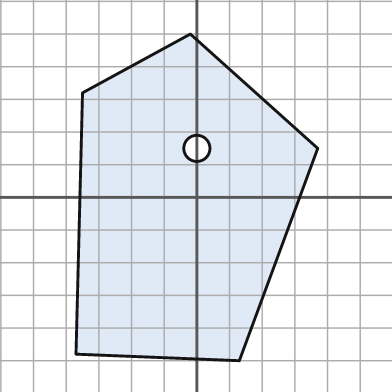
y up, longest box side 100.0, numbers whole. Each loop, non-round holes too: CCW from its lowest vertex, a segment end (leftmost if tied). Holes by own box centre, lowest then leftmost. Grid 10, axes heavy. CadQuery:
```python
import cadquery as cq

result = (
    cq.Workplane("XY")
    .moveTo(13.0, -50.0)
    .lineTo(37.0, 15.0)
    .lineTo(-2.0, 50.0)
    .lineTo(-35.0, 32.0)
    .lineTo(-37.0, -48.0)
    .close()
    .moveTo(0.0, 15.0)
    .circle(4.0)
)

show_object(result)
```